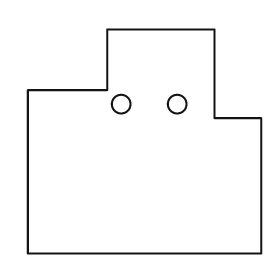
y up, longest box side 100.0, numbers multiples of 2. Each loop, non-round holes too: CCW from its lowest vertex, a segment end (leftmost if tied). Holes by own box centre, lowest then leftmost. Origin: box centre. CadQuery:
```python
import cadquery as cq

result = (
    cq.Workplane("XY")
    .moveTo(-50.0, -48.0)
    .lineTo(50.0, -48.0)
    .lineTo(50.0, 10.0)
    .lineTo(30.0, 10.0)
    .lineTo(30.0, 48.0)
    .lineTo(-16.0, 48.0)
    .lineTo(-16.0, 22.0)
    .lineTo(-50.0, 22.0)
    .close()
    .moveTo(-10.0, 16.0)
    .circle(4.0)
    .moveTo(14.0, 16.0)
    .circle(4.0)
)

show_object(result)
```